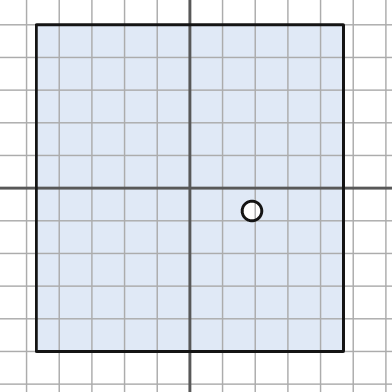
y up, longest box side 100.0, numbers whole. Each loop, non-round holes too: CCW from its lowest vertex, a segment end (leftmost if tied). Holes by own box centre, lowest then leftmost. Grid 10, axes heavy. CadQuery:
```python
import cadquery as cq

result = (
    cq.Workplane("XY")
    .moveTo(-47.0, -50.0)
    .lineTo(47.0, -50.0)
    .lineTo(47.0, 50.0)
    .lineTo(-47.0, 50.0)
    .close()
    .moveTo(19.0, -7.0)
    .circle(3.0)
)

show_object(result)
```